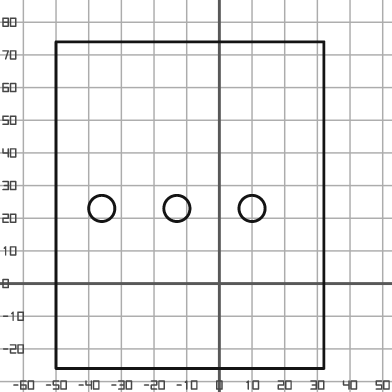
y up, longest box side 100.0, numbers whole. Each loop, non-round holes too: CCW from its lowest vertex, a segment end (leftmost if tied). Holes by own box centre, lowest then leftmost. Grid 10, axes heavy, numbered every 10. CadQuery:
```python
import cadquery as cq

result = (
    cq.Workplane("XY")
    .moveTo(-50.0, -26.0)
    .lineTo(32.0, -26.0)
    .lineTo(32.0, 74.0)
    .lineTo(-50.0, 74.0)
    .close()
    .moveTo(-36.0, 23.0)
    .circle(4.0)
    .moveTo(-13.0, 23.0)
    .circle(4.0)
    .moveTo(10.0, 23.0)
    .circle(4.0)
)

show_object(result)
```